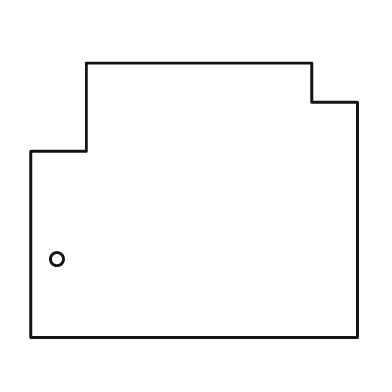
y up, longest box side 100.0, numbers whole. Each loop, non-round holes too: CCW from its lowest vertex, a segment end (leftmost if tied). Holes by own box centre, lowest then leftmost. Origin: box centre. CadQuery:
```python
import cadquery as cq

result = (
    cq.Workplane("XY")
    .moveTo(-50.0, -42.0)
    .lineTo(50.0, -42.0)
    .lineTo(50.0, 30.0)
    .lineTo(36.0, 30.0)
    .lineTo(36.0, 42.0)
    .lineTo(-33.0, 42.0)
    .lineTo(-33.0, 15.0)
    .lineTo(-50.0, 15.0)
    .close()
    .moveTo(-42.0, -18.0)
    .circle(2.0)
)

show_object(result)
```